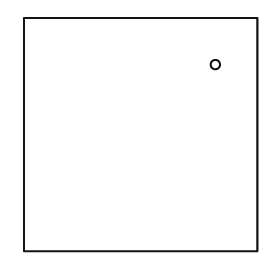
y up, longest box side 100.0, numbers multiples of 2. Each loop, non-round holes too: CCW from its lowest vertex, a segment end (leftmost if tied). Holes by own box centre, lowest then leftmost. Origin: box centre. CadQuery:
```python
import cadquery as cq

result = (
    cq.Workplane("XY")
    .moveTo(-50.0, -50.0)
    .lineTo(50.0, -50.0)
    .lineTo(50.0, 50.0)
    .lineTo(-50.0, 50.0)
    .close()
    .moveTo(32.0, 30.0)
    .circle(2.0)
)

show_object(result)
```